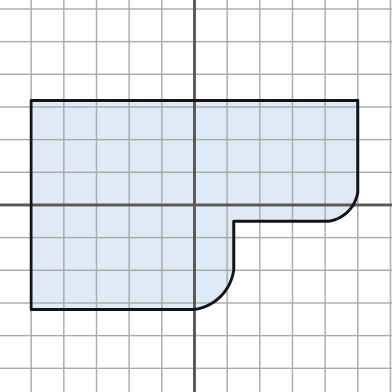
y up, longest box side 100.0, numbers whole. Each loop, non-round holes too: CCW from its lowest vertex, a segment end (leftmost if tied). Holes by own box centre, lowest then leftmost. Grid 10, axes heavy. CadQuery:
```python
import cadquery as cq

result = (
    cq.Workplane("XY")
    .moveTo(-50.0, -32.0)
    .lineTo(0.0, -32.0)
    .threePointArc((8.0, -28.0), (12.0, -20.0))
    .lineTo(12.0, -5.0)
    .lineTo(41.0, -5.0)
    .threePointArc((47.0, -2.0), (50.0, 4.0))
    .lineTo(50.0, 32.0)
    .lineTo(-50.0, 32.0)
    .close()
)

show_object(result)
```